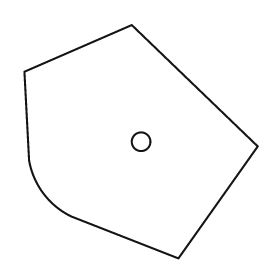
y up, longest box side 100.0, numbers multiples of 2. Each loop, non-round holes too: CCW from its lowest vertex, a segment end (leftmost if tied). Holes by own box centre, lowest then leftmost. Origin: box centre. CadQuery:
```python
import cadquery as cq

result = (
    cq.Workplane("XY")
    .moveTo(16.0, -50.0)
    .lineTo(50.0, -2.0)
    .lineTo(-4.0, 50.0)
    .lineTo(-50.0, 30.0)
    .lineTo(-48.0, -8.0)
    .threePointArc((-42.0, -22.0), (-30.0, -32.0))
    .close()
    .moveTo(0.0, 0.0)
    .circle(4.0)
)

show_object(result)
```